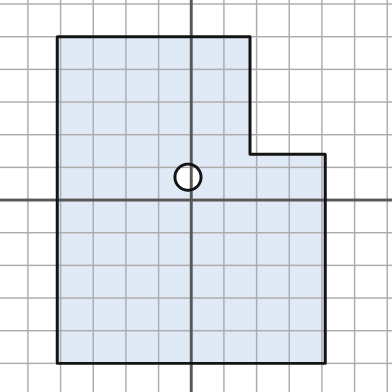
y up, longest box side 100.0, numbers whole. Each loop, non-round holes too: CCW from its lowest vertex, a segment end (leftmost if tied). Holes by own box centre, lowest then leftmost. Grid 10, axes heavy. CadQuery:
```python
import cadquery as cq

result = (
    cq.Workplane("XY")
    .moveTo(-41.0, -50.0)
    .lineTo(41.0, -50.0)
    .lineTo(41.0, 14.0)
    .lineTo(18.0, 14.0)
    .lineTo(18.0, 50.0)
    .lineTo(-41.0, 50.0)
    .close()
    .moveTo(-1.0, 7.0)
    .circle(4.0)
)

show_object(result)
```